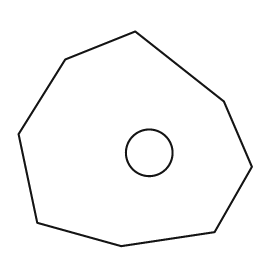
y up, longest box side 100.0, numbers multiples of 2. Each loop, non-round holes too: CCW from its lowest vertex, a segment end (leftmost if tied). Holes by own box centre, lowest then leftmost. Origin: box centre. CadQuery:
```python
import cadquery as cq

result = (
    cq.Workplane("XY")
    .moveTo(-6.0, -46.0)
    .lineTo(34.0, -40.0)
    .lineTo(50.0, -12.0)
    .lineTo(38.0, 16.0)
    .lineTo(0.0, 46.0)
    .lineTo(-30.0, 34.0)
    .lineTo(-50.0, 2.0)
    .lineTo(-42.0, -36.0)
    .close()
    .moveTo(6.0, -6.0)
    .circle(10.0)
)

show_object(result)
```